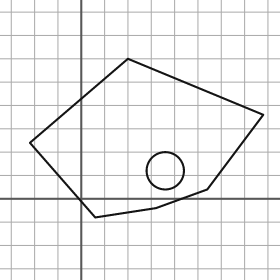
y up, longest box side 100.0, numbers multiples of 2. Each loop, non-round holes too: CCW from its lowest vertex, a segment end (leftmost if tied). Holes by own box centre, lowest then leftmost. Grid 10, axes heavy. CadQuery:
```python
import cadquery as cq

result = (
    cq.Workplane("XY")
    .moveTo(6.0, -8.0)
    .lineTo(32.0, -4.0)
    .lineTo(54.0, 4.0)
    .lineTo(78.0, 36.0)
    .lineTo(20.0, 60.0)
    .lineTo(-22.0, 24.0)
    .close()
    .moveTo(36.0, 12.0)
    .circle(8.0)
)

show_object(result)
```